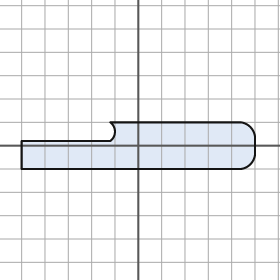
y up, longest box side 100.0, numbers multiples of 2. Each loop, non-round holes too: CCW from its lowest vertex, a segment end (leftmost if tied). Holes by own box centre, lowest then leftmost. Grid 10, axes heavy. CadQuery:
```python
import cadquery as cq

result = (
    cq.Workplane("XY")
    .moveTo(-50.0, -10.0)
    .lineTo(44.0, -10.0)
    .threePointArc((48.0, -8.0), (50.0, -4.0))
    .lineTo(50.0, 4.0)
    .threePointArc((48.0, 8.0), (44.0, 10.0))
    .lineTo(-12.0, 10.0)
    .threePointArc((-10.0, 6.0), (-12.0, 2.0))
    .lineTo(-50.0, 2.0)
    .close()
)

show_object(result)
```